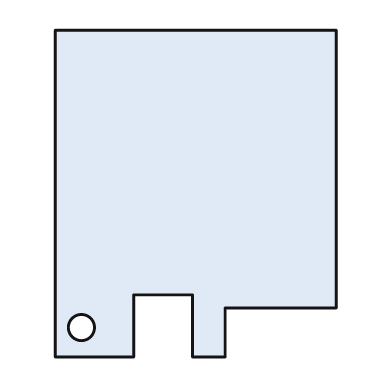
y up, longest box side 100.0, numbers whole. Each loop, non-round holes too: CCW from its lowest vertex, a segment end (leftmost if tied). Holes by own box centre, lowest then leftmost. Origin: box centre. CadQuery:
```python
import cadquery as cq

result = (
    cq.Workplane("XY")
    .moveTo(-43.0, -50.0)
    .lineTo(-19.0, -50.0)
    .lineTo(-19.0, -31.0)
    .lineTo(-1.0, -31.0)
    .lineTo(-1.0, -50.0)
    .lineTo(9.0, -50.0)
    .lineTo(9.0, -35.0)
    .lineTo(43.0, -35.0)
    .lineTo(43.0, 50.0)
    .lineTo(-43.0, 50.0)
    .close()
    .moveTo(-35.0, -41.0)
    .circle(4.0)
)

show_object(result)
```